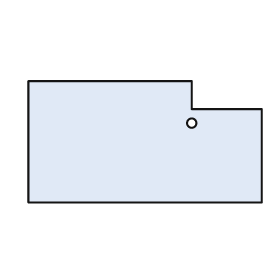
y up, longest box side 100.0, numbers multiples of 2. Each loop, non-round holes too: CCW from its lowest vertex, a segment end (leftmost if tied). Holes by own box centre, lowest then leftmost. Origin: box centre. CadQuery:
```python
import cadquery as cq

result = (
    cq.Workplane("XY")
    .moveTo(-50.0, -26.0)
    .lineTo(50.0, -26.0)
    .lineTo(50.0, 14.0)
    .lineTo(20.0, 14.0)
    .lineTo(20.0, 26.0)
    .lineTo(-50.0, 26.0)
    .close()
    .moveTo(20.0, 8.0)
    .circle(2.0)
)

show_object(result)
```